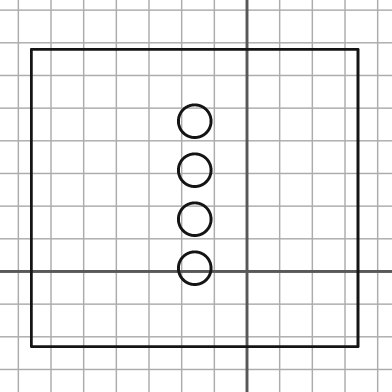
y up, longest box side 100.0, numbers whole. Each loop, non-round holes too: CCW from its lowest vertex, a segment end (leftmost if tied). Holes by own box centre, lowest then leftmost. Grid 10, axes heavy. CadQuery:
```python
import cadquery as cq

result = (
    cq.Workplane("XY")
    .moveTo(-66.0, -23.0)
    .lineTo(34.0, -23.0)
    .lineTo(34.0, 68.0)
    .lineTo(-66.0, 68.0)
    .close()
    .moveTo(-16.0, 1.0)
    .circle(5.0)
    .moveTo(-16.0, 16.0)
    .circle(5.0)
    .moveTo(-16.0, 31.0)
    .circle(5.0)
    .moveTo(-16.0, 46.0)
    .circle(5.0)
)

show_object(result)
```